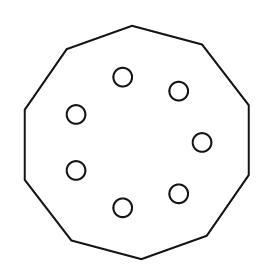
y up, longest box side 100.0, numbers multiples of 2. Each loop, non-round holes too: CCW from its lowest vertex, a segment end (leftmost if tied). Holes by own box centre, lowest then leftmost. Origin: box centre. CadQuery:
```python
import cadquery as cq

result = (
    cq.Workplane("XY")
    .moveTo(2.0, -50.0)
    .lineTo(30.0, -40.0)
    .lineTo(48.0, -14.0)
    .lineTo(48.0, 16.0)
    .lineTo(28.0, 42.0)
    .lineTo(-2.0, 50.0)
    .lineTo(-30.0, 40.0)
    .lineTo(-48.0, 14.0)
    .lineTo(-48.0, -16.0)
    .lineTo(-28.0, -42.0)
    .close()
    .moveTo(-6.0, -28.0)
    .circle(4.0)
    .moveTo(18.0, -22.0)
    .circle(4.0)
    .moveTo(-26.0, -12.0)
    .circle(4.0)
    .moveTo(28.0, 0.0)
    .circle(4.0)
    .moveTo(-26.0, 12.0)
    .circle(4.0)
    .moveTo(18.0, 22.0)
    .circle(4.0)
    .moveTo(-6.0, 28.0)
    .circle(4.0)
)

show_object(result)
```